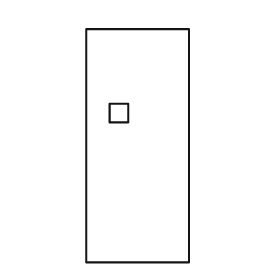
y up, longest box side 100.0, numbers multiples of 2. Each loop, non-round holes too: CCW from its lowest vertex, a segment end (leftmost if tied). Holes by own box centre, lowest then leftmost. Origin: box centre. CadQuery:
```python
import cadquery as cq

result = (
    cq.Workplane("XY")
    .moveTo(-22.0, -50.0)
    .lineTo(22.0, -50.0)
    .lineTo(22.0, 50.0)
    .lineTo(-22.0, 50.0)
    .close()
    .moveTo(-12.0, 10.0)
    .lineTo(-4.0, 10.0)
    .lineTo(-4.0, 18.0)
    .lineTo(-12.0, 18.0)
    .close()
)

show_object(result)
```